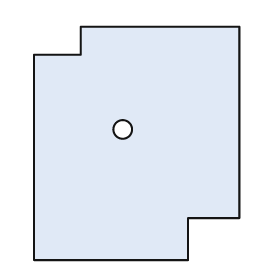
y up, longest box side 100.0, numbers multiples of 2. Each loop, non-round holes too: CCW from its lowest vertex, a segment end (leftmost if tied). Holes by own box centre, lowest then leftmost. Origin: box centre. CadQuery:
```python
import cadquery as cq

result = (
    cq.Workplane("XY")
    .moveTo(-44.0, -50.0)
    .lineTo(22.0, -50.0)
    .lineTo(22.0, -32.0)
    .lineTo(44.0, -32.0)
    .lineTo(44.0, 50.0)
    .lineTo(-24.0, 50.0)
    .lineTo(-24.0, 38.0)
    .lineTo(-44.0, 38.0)
    .close()
    .moveTo(-6.0, 6.0)
    .circle(4.0)
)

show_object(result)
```